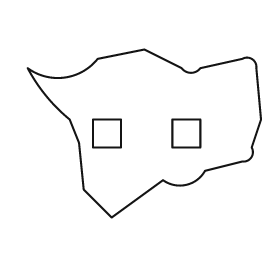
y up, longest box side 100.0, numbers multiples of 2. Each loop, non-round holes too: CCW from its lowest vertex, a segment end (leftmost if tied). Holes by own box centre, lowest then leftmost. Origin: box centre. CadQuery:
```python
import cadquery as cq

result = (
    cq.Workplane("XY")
    .moveTo(-14.0, -36.0)
    .lineTo(8.0, -20.0)
    .threePointArc((18.0, -22.0), (26.0, -16.0))
    .lineTo(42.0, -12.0)
    .threePointArc((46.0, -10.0), (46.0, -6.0))
    .lineTo(50.0, 6.0)
    .lineTo(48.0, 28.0)
    .threePointArc((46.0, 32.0), (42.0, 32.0))
    .lineTo(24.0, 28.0)
    .threePointArc((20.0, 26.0), (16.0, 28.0))
    .lineTo(0.0, 36.0)
    .lineTo(-20.0, 32.0)
    .threePointArc((-34.0, 24.0), (-50.0, 28.0))
    .threePointArc((-42.0, 16.0), (-32.0, 6.0))
    .lineTo(-28.0, -4.0)
    .lineTo(-26.0, -24.0)
    .close()
    .moveTo(-22.0, -6.0)
    .lineTo(-10.0, -6.0)
    .lineTo(-10.0, 6.0)
    .lineTo(-22.0, 6.0)
    .close()
    .moveTo(12.0, -6.0)
    .lineTo(24.0, -6.0)
    .lineTo(24.0, 6.0)
    .lineTo(12.0, 6.0)
    .close()
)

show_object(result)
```